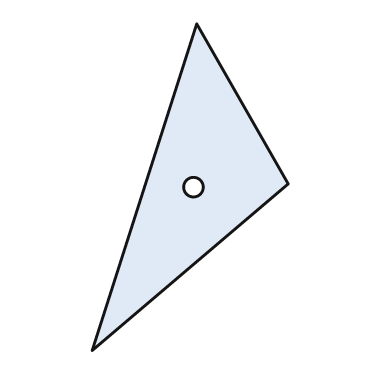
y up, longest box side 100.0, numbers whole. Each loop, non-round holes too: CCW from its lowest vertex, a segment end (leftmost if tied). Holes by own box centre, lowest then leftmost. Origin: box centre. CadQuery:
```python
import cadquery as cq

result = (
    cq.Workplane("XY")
    .moveTo(-30.0, -50.0)
    .lineTo(30.0, 1.0)
    .lineTo(2.0, 50.0)
    .close()
    .moveTo(1.0, 0.0)
    .circle(3.0)
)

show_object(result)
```